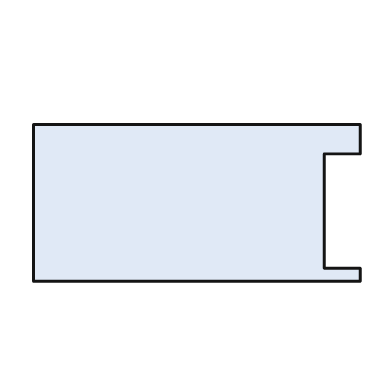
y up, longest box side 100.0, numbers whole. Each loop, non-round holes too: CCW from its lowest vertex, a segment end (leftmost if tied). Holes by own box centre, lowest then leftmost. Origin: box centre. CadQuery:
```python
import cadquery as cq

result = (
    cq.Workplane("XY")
    .moveTo(-50.0, -24.0)
    .lineTo(50.0, -24.0)
    .lineTo(50.0, -20.0)
    .lineTo(39.0, -20.0)
    .lineTo(39.0, 15.0)
    .lineTo(50.0, 15.0)
    .lineTo(50.0, 24.0)
    .lineTo(-50.0, 24.0)
    .close()
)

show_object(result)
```